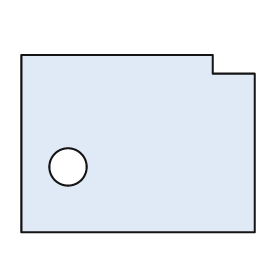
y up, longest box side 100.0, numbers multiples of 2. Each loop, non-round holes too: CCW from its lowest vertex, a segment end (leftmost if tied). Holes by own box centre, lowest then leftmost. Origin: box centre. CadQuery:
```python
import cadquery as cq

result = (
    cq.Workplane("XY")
    .moveTo(-50.0, -38.0)
    .lineTo(50.0, -38.0)
    .lineTo(50.0, 30.0)
    .lineTo(32.0, 30.0)
    .lineTo(32.0, 38.0)
    .lineTo(-50.0, 38.0)
    .close()
    .moveTo(-30.0, -10.0)
    .circle(8.0)
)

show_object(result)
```